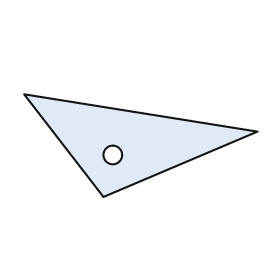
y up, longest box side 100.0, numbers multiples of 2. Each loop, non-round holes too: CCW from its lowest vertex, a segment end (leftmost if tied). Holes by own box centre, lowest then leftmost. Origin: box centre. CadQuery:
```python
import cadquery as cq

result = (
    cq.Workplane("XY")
    .moveTo(-16.0, -22.0)
    .lineTo(50.0, 6.0)
    .lineTo(-50.0, 22.0)
    .close()
    .moveTo(-12.0, -4.0)
    .circle(4.0)
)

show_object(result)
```